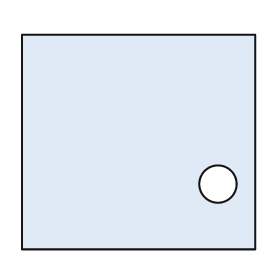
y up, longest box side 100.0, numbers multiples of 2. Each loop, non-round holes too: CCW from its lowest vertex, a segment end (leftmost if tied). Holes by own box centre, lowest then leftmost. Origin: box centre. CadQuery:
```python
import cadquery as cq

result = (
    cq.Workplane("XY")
    .moveTo(-50.0, -46.0)
    .lineTo(50.0, -46.0)
    .lineTo(50.0, 46.0)
    .lineTo(-50.0, 46.0)
    .close()
    .moveTo(34.0, -18.0)
    .circle(8.0)
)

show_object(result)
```